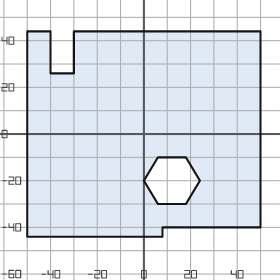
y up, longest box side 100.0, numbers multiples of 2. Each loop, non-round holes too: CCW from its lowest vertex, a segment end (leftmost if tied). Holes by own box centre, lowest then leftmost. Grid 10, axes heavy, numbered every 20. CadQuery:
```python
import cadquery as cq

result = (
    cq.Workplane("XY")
    .moveTo(-50.0, -44.0)
    .lineTo(8.0, -44.0)
    .lineTo(8.0, -40.0)
    .lineTo(50.0, -40.0)
    .lineTo(50.0, 44.0)
    .lineTo(-30.0, 44.0)
    .lineTo(-30.0, 26.0)
    .lineTo(-40.0, 26.0)
    .lineTo(-40.0, 44.0)
    .lineTo(-50.0, 44.0)
    .close()
    .moveTo(6.0, -30.0)
    .lineTo(18.0, -30.0)
    .lineTo(24.0, -20.0)
    .lineTo(18.0, -10.0)
    .lineTo(6.0, -10.0)
    .lineTo(0.0, -20.0)
    .close()
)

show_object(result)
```